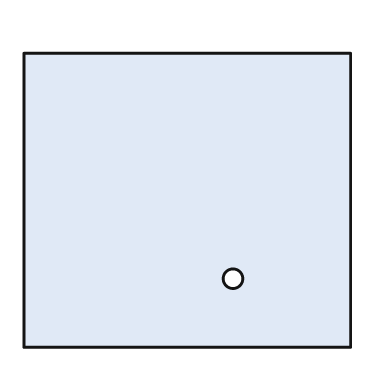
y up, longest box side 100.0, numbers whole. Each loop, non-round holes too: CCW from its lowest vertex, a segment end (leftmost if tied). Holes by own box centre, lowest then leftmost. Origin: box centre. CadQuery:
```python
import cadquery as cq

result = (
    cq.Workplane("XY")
    .moveTo(-50.0, -45.0)
    .lineTo(50.0, -45.0)
    .lineTo(50.0, 45.0)
    .lineTo(-50.0, 45.0)
    .close()
    .moveTo(14.0, -24.0)
    .circle(3.0)
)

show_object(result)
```